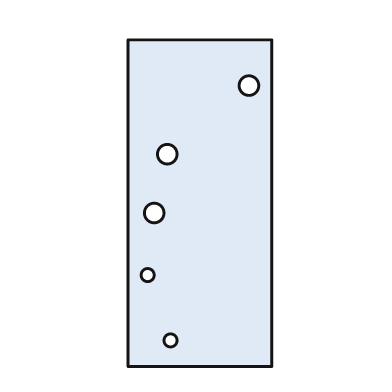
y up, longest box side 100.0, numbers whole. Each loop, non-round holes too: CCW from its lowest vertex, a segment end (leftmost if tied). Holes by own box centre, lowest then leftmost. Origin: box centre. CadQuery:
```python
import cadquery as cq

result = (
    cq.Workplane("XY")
    .moveTo(-22.0, -50.0)
    .lineTo(22.0, -50.0)
    .lineTo(22.0, 50.0)
    .lineTo(-22.0, 50.0)
    .close()
    .moveTo(-9.0, -42.0)
    .circle(2.0)
    .moveTo(-16.0, -22.0)
    .circle(2.0)
    .moveTo(-14.0, -3.0)
    .circle(3.0)
    .moveTo(-10.0, 15.0)
    .circle(3.0)
    .moveTo(15.0, 36.0)
    .circle(3.0)
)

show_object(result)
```